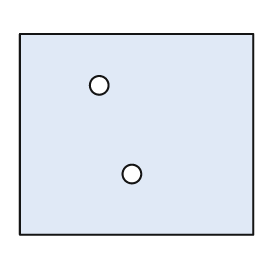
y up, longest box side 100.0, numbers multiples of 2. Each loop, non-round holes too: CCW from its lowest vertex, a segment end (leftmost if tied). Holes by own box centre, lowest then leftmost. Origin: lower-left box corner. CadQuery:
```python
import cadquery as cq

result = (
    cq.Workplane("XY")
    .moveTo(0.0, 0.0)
    .lineTo(100.0, 0.0)
    .lineTo(100.0, 86.0)
    .lineTo(0.0, 86.0)
    .close()
    .moveTo(48.0, 26.0)
    .circle(4.0)
    .moveTo(34.0, 64.0)
    .circle(4.0)
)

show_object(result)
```